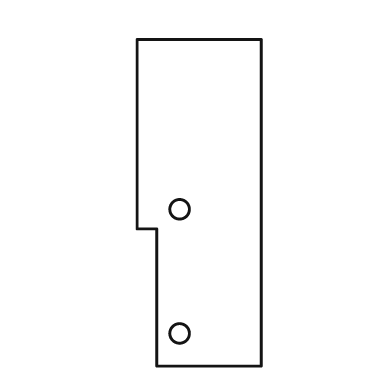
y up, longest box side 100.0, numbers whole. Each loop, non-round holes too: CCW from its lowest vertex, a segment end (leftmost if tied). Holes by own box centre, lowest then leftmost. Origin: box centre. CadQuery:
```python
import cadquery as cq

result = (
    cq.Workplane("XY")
    .moveTo(-13.0, -50.0)
    .lineTo(19.0, -50.0)
    .lineTo(19.0, 50.0)
    .lineTo(-19.0, 50.0)
    .lineTo(-19.0, -8.0)
    .lineTo(-13.0, -8.0)
    .close()
    .moveTo(-6.0, -40.0)
    .circle(3.0)
    .moveTo(-6.0, -2.0)
    .circle(3.0)
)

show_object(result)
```